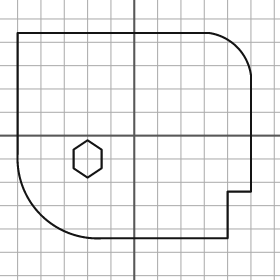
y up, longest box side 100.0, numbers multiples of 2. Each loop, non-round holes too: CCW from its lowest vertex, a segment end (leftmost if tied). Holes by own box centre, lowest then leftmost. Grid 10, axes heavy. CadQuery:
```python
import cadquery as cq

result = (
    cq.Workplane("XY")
    .moveTo(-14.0, -44.0)
    .lineTo(40.0, -44.0)
    .lineTo(40.0, -24.0)
    .lineTo(50.0, -24.0)
    .lineTo(50.0, 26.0)
    .threePointArc((44.0, 38.0), (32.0, 44.0))
    .lineTo(-50.0, 44.0)
    .lineTo(-50.0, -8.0)
    .threePointArc((-40.0, -34.0), (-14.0, -44.0))
    .close()
    .moveTo(-20.0, -18.0)
    .lineTo(-14.0, -14.0)
    .lineTo(-14.0, -6.0)
    .lineTo(-20.0, -2.0)
    .lineTo(-26.0, -6.0)
    .lineTo(-26.0, -14.0)
    .close()
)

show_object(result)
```